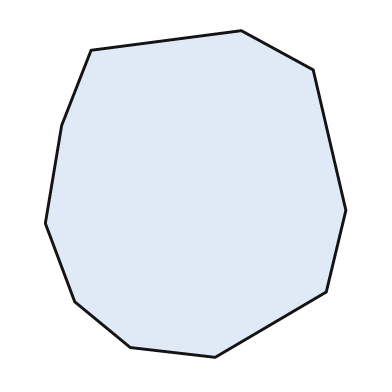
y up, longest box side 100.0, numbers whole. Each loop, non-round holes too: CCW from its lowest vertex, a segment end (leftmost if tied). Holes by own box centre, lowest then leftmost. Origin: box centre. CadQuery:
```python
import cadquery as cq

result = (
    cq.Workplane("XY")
    .moveTo(6.0, -50.0)
    .lineTo(40.0, -30.0)
    .lineTo(46.0, -5.0)
    .lineTo(36.0, 38.0)
    .lineTo(14.0, 50.0)
    .lineTo(-32.0, 44.0)
    .lineTo(-41.0, 21.0)
    .lineTo(-46.0, -9.0)
    .lineTo(-37.0, -33.0)
    .lineTo(-20.0, -47.0)
    .close()
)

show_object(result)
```